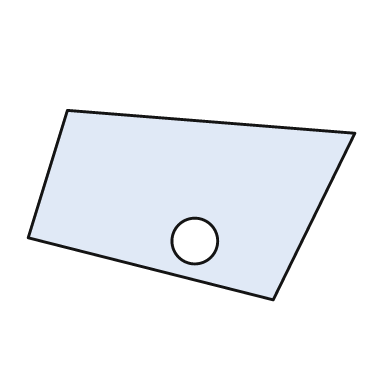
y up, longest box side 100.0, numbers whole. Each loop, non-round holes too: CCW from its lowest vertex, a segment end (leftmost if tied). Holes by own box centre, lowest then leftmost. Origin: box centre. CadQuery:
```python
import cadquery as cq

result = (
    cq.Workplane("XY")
    .moveTo(25.0, -29.0)
    .lineTo(50.0, 22.0)
    .lineTo(-38.0, 29.0)
    .lineTo(-50.0, -10.0)
    .close()
    .moveTo(1.0, -11.0)
    .circle(7.0)
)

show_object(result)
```